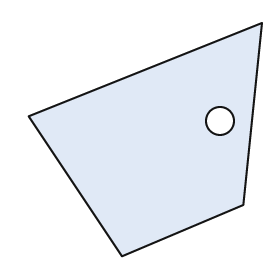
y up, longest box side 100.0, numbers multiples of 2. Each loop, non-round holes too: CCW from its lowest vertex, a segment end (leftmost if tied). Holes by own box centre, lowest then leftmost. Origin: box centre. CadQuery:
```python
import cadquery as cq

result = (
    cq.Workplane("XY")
    .moveTo(-10.0, -50.0)
    .lineTo(42.0, -28.0)
    .lineTo(50.0, 50.0)
    .lineTo(-50.0, 10.0)
    .close()
    .moveTo(32.0, 8.0)
    .circle(6.0)
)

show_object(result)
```